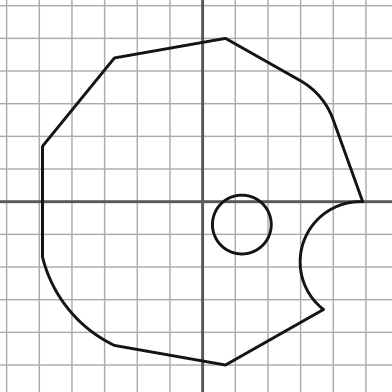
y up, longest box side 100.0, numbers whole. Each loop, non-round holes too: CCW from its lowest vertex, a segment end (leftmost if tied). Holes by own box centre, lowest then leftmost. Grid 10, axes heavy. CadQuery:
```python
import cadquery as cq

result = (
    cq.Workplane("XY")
    .moveTo(7.0, -50.0)
    .lineTo(37.0, -33.0)
    .threePointArc((31.0, -12.0), (49.0, 0.0))
    .lineTo(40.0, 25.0)
    .threePointArc((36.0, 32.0), (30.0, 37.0))
    .lineTo(7.0, 50.0)
    .lineTo(-27.0, 44.0)
    .lineTo(-49.0, 17.0)
    .lineTo(-49.0, -17.0)
    .threePointArc((-41.0, -33.0), (-27.0, -44.0))
    .close()
    .moveTo(12.0, -7.0)
    .circle(9.0)
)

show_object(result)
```